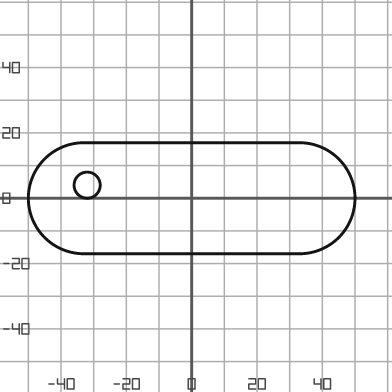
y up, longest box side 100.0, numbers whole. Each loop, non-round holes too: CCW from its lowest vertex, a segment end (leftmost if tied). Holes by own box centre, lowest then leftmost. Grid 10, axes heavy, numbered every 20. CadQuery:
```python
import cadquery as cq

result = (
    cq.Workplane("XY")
    .moveTo(-33.0, -17.0)
    .lineTo(33.0, -17.0)
    .threePointArc((50.0, 0.0), (33.0, 17.0))
    .lineTo(-33.0, 17.0)
    .threePointArc((-50.0, 0.0), (-33.0, -17.0))
    .close()
    .moveTo(-32.0, 4.0)
    .circle(4.0)
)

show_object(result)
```